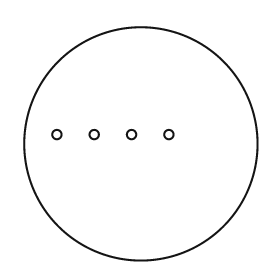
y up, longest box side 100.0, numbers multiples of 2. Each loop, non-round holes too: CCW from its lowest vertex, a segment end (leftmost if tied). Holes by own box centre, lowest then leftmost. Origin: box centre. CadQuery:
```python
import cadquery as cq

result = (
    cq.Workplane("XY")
    .moveTo(0.0, 0.0)
    .circle(50.0)
    .moveTo(-36.0, 4.0)
    .circle(2.0)
    .moveTo(-20.0, 4.0)
    .circle(2.0)
    .moveTo(-4.0, 4.0)
    .circle(2.0)
    .moveTo(12.0, 4.0)
    .circle(2.0)
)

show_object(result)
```